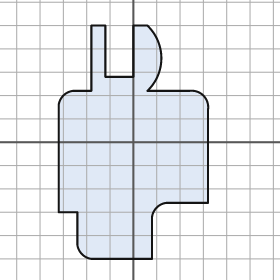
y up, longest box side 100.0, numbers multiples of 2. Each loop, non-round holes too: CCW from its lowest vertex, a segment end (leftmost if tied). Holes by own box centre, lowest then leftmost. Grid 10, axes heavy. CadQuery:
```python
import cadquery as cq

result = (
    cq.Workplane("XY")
    .moveTo(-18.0, -50.0)
    .lineTo(8.0, -50.0)
    .lineTo(8.0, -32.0)
    .threePointArc((10.0, -28.0), (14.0, -26.0))
    .lineTo(32.0, -26.0)
    .lineTo(32.0, 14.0)
    .threePointArc((30.0, 20.0), (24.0, 22.0))
    .lineTo(6.0, 22.0)
    .threePointArc((12.0, 36.0), (6.0, 50.0))
    .lineTo(0.0, 50.0)
    .lineTo(0.0, 28.0)
    .lineTo(-12.0, 28.0)
    .lineTo(-12.0, 50.0)
    .lineTo(-18.0, 50.0)
    .lineTo(-18.0, 22.0)
    .lineTo(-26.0, 22.0)
    .threePointArc((-30.0, 20.0), (-32.0, 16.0))
    .lineTo(-32.0, -30.0)
    .lineTo(-24.0, -30.0)
    .lineTo(-24.0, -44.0)
    .threePointArc((-22.0, -48.0), (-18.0, -50.0))
    .close()
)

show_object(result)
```